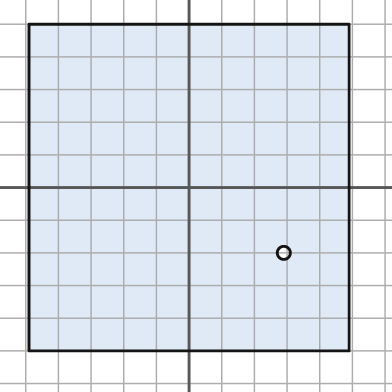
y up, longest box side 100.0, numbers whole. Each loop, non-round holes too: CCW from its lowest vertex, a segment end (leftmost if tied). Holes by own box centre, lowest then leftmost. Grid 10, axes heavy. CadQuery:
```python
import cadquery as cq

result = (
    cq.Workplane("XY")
    .moveTo(-49.0, -50.0)
    .lineTo(49.0, -50.0)
    .lineTo(49.0, 50.0)
    .lineTo(-49.0, 50.0)
    .close()
    .moveTo(29.0, -20.0)
    .circle(2.0)
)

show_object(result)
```